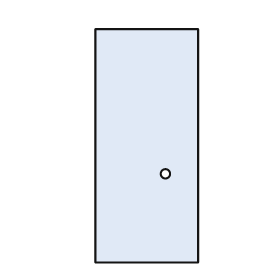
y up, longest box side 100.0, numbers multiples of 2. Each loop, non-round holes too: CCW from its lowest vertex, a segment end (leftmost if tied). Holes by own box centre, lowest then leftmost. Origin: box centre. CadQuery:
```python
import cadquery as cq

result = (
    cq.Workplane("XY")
    .moveTo(-22.0, -50.0)
    .lineTo(22.0, -50.0)
    .lineTo(22.0, 50.0)
    .lineTo(-22.0, 50.0)
    .close()
    .moveTo(8.0, -12.0)
    .circle(2.0)
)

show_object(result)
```